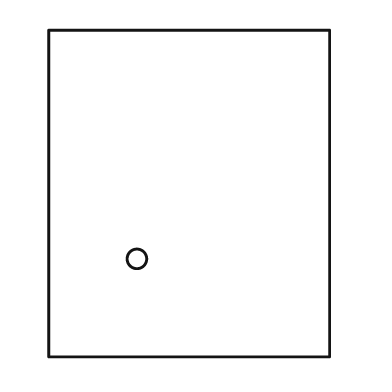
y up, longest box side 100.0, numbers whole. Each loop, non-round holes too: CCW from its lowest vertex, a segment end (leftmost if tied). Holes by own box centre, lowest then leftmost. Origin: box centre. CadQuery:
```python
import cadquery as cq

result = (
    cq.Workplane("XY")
    .moveTo(-43.0, -50.0)
    .lineTo(43.0, -50.0)
    .lineTo(43.0, 50.0)
    .lineTo(-43.0, 50.0)
    .close()
    .moveTo(-16.0, -20.0)
    .circle(3.0)
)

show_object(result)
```